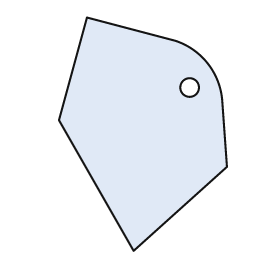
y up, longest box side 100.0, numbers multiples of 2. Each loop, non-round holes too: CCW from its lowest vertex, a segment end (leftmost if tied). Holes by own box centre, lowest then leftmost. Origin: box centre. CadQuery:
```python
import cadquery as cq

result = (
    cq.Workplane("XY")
    .moveTo(-4.0, -50.0)
    .lineTo(36.0, -14.0)
    .lineTo(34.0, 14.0)
    .threePointArc((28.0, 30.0), (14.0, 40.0))
    .lineTo(-24.0, 50.0)
    .lineTo(-36.0, 6.0)
    .close()
    .moveTo(20.0, 20.0)
    .circle(4.0)
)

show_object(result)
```